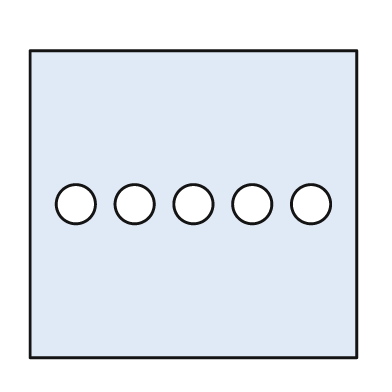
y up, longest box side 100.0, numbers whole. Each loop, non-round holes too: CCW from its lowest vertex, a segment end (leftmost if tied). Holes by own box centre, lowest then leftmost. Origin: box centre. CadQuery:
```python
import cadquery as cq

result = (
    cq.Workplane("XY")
    .moveTo(-50.0, -47.0)
    .lineTo(50.0, -47.0)
    .lineTo(50.0, 47.0)
    .lineTo(-50.0, 47.0)
    .close()
    .moveTo(-36.0, 0.0)
    .circle(6.0)
    .moveTo(-18.0, 0.0)
    .circle(6.0)
    .moveTo(0.0, 0.0)
    .circle(6.0)
    .moveTo(18.0, 0.0)
    .circle(6.0)
    .moveTo(36.0, 0.0)
    .circle(6.0)
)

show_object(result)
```